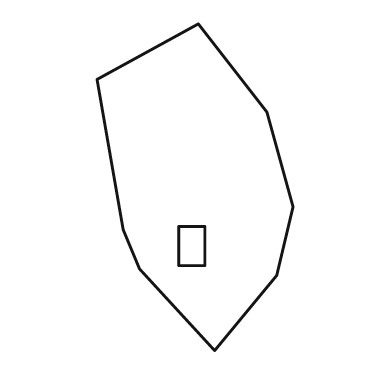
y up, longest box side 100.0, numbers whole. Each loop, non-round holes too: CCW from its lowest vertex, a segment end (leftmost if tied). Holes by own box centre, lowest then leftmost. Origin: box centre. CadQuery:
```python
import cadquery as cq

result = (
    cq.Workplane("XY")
    .moveTo(6.0, -50.0)
    .lineTo(25.0, -27.0)
    .lineTo(30.0, -6.0)
    .lineTo(22.0, 23.0)
    .lineTo(1.0, 50.0)
    .lineTo(-30.0, 33.0)
    .lineTo(-22.0, -13.0)
    .lineTo(-17.0, -25.0)
    .close()
    .moveTo(-5.0, -24.0)
    .lineTo(3.0, -24.0)
    .lineTo(3.0, -12.0)
    .lineTo(-5.0, -12.0)
    .close()
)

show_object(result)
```